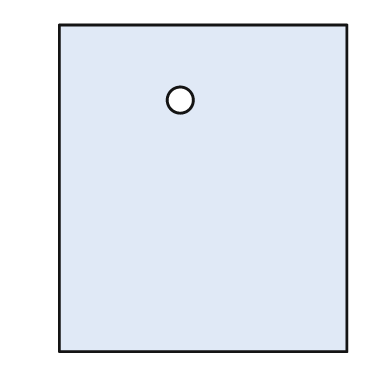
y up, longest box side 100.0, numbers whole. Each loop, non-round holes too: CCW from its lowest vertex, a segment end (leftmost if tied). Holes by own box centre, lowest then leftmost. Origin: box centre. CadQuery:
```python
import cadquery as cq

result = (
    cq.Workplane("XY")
    .moveTo(-44.0, -50.0)
    .lineTo(44.0, -50.0)
    .lineTo(44.0, 50.0)
    .lineTo(-44.0, 50.0)
    .close()
    .moveTo(-7.0, 27.0)
    .circle(4.0)
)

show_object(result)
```